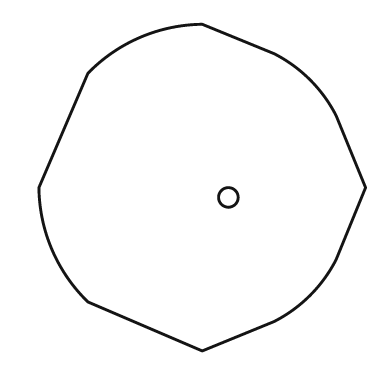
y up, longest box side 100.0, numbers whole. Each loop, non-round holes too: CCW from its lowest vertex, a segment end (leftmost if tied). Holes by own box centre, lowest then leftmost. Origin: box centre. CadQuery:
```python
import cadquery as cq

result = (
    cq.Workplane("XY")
    .moveTo(0.0, -50.0)
    .lineTo(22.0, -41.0)
    .threePointArc((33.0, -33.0), (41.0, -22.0))
    .lineTo(50.0, 0.0)
    .lineTo(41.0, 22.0)
    .threePointArc((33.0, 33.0), (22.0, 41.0))
    .lineTo(0.0, 50.0)
    .threePointArc((-19.0, 46.0), (-35.0, 35.0))
    .lineTo(-50.0, 0.0)
    .threePointArc((-46.0, -19.0), (-35.0, -35.0))
    .close()
    .moveTo(8.0, -3.0)
    .circle(3.0)
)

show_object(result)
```